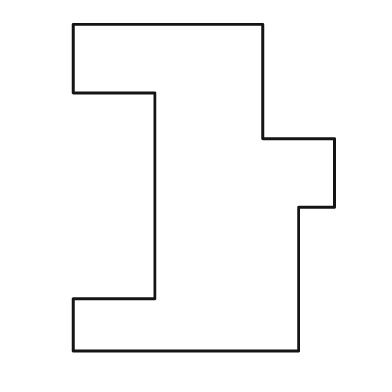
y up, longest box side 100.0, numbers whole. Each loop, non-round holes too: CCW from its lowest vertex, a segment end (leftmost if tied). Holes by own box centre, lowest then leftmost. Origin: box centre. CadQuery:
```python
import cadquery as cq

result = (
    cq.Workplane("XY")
    .moveTo(-40.0, -50.0)
    .lineTo(29.0, -50.0)
    .lineTo(29.0, -6.0)
    .lineTo(40.0, -6.0)
    .lineTo(40.0, 15.0)
    .lineTo(18.0, 15.0)
    .lineTo(18.0, 50.0)
    .lineTo(-40.0, 50.0)
    .lineTo(-40.0, 29.0)
    .lineTo(-15.0, 29.0)
    .lineTo(-15.0, -34.0)
    .lineTo(-40.0, -34.0)
    .close()
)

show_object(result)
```